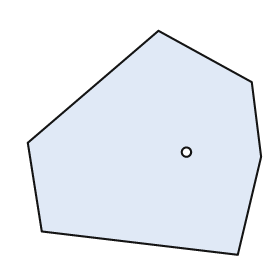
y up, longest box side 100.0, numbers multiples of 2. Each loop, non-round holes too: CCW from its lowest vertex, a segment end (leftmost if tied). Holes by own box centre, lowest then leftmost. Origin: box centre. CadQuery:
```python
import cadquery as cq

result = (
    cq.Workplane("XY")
    .moveTo(40.0, -48.0)
    .lineTo(50.0, -6.0)
    .lineTo(46.0, 26.0)
    .lineTo(6.0, 48.0)
    .lineTo(-50.0, 0.0)
    .lineTo(-44.0, -38.0)
    .close()
    .moveTo(18.0, -4.0)
    .circle(2.0)
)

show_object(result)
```